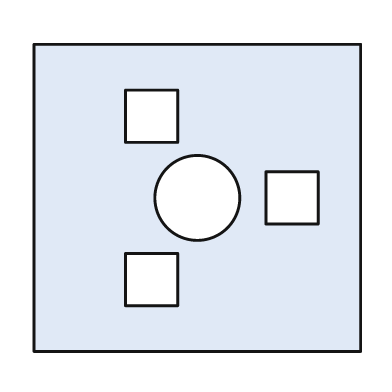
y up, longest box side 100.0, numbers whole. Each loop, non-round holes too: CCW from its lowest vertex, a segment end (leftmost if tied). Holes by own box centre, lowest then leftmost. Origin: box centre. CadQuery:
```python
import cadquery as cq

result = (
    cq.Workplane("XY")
    .moveTo(-50.0, -47.0)
    .lineTo(50.0, -47.0)
    .lineTo(50.0, 47.0)
    .lineTo(-50.0, 47.0)
    .close()
    .moveTo(-22.0, -33.0)
    .lineTo(-6.0, -33.0)
    .lineTo(-6.0, -17.0)
    .lineTo(-22.0, -17.0)
    .close()
    .moveTo(0.0, 0.0)
    .circle(13.0)
    .moveTo(21.0, -8.0)
    .lineTo(37.0, -8.0)
    .lineTo(37.0, 8.0)
    .lineTo(21.0, 8.0)
    .close()
    .moveTo(-22.0, 17.0)
    .lineTo(-6.0, 17.0)
    .lineTo(-6.0, 33.0)
    .lineTo(-22.0, 33.0)
    .close()
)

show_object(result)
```